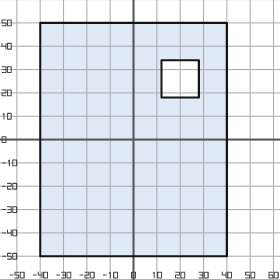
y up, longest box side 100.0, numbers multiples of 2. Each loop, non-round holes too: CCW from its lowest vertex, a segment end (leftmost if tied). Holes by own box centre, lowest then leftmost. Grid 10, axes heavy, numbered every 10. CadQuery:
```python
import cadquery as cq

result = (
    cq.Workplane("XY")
    .moveTo(-40.0, -50.0)
    .lineTo(40.0, -50.0)
    .lineTo(40.0, 50.0)
    .lineTo(-40.0, 50.0)
    .close()
    .moveTo(12.0, 18.0)
    .lineTo(28.0, 18.0)
    .lineTo(28.0, 34.0)
    .lineTo(12.0, 34.0)
    .close()
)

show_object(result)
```